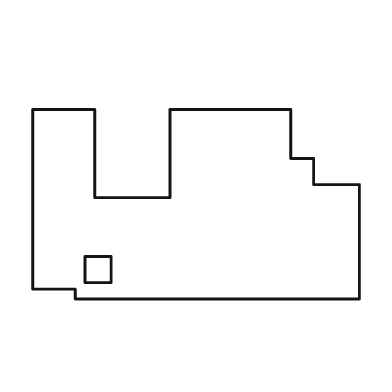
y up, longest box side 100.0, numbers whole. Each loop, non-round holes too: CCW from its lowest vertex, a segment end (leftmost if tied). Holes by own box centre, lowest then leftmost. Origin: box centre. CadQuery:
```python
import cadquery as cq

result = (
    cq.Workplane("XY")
    .moveTo(-37.0, -29.0)
    .lineTo(50.0, -29.0)
    .lineTo(50.0, 6.0)
    .lineTo(36.0, 6.0)
    .lineTo(36.0, 14.0)
    .lineTo(29.0, 14.0)
    .lineTo(29.0, 29.0)
    .lineTo(-8.0, 29.0)
    .lineTo(-8.0, 2.0)
    .lineTo(-31.0, 2.0)
    .lineTo(-31.0, 29.0)
    .lineTo(-50.0, 29.0)
    .lineTo(-50.0, -26.0)
    .lineTo(-37.0, -26.0)
    .close()
    .moveTo(-34.0, -24.0)
    .lineTo(-26.0, -24.0)
    .lineTo(-26.0, -16.0)
    .lineTo(-34.0, -16.0)
    .close()
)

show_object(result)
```